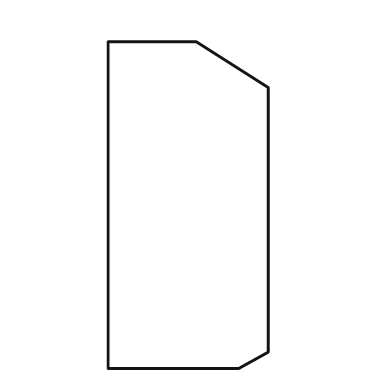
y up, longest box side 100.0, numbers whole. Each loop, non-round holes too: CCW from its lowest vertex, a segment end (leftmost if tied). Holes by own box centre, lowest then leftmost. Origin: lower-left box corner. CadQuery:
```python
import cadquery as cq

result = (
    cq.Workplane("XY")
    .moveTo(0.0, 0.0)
    .lineTo(40.0, 0.0)
    .lineTo(49.0, 5.0)
    .lineTo(49.0, 86.0)
    .lineTo(27.0, 100.0)
    .lineTo(0.0, 100.0)
    .close()
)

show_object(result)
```